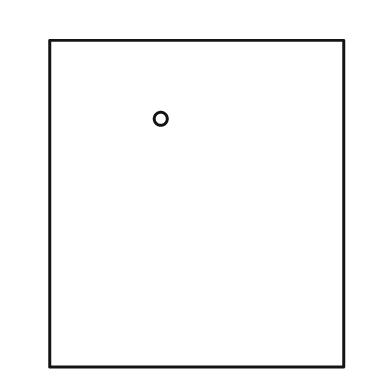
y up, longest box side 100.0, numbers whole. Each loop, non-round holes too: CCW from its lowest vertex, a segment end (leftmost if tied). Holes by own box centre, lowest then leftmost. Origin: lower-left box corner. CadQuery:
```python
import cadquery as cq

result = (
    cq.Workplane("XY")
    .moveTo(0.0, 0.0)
    .lineTo(90.0, 0.0)
    .lineTo(90.0, 100.0)
    .lineTo(0.0, 100.0)
    .close()
    .moveTo(34.0, 76.0)
    .circle(2.0)
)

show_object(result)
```